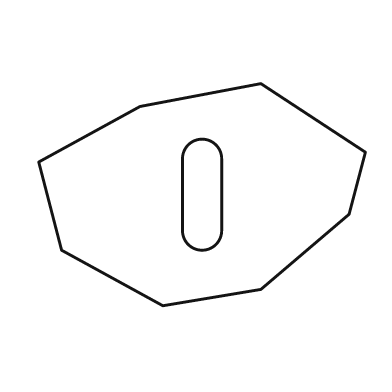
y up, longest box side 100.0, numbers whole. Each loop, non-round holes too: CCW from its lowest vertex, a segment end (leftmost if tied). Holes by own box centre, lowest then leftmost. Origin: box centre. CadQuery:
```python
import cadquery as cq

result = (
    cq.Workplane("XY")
    .moveTo(-12.0, -34.0)
    .lineTo(18.0, -29.0)
    .lineTo(45.0, -6.0)
    .lineTo(50.0, 13.0)
    .lineTo(18.0, 34.0)
    .lineTo(-19.0, 27.0)
    .lineTo(-50.0, 10.0)
    .lineTo(-43.0, -17.0)
    .close()
    .moveTo(-6.0, -11.0)
    .threePointArc((0.0, -17.0), (6.0, -11.0))
    .lineTo(6.0, 11.0)
    .threePointArc((0.0, 17.0), (-6.0, 11.0))
    .close()
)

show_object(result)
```